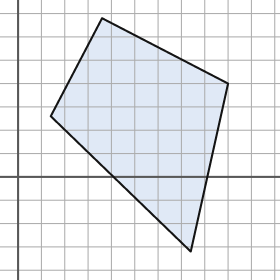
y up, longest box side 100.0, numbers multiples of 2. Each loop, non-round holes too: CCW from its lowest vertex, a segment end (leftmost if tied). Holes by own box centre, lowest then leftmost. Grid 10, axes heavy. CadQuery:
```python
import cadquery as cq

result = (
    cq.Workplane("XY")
    .moveTo(74.0, -32.0)
    .lineTo(90.0, 40.0)
    .lineTo(36.0, 68.0)
    .lineTo(14.0, 26.0)
    .close()
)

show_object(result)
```